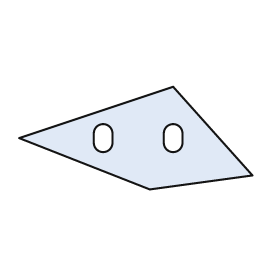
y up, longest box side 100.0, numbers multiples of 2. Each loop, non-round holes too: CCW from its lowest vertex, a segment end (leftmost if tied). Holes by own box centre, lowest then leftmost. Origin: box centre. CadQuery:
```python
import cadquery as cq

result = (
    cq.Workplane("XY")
    .moveTo(6.0, -22.0)
    .lineTo(50.0, -16.0)
    .lineTo(16.0, 22.0)
    .lineTo(-50.0, 0.0)
    .close()
    .moveTo(-18.0, -2.0)
    .threePointArc((-14.0, -6.0), (-10.0, -2.0))
    .lineTo(-10.0, 2.0)
    .threePointArc((-14.0, 6.0), (-18.0, 2.0))
    .close()
    .moveTo(12.0, -2.0)
    .threePointArc((16.0, -6.0), (20.0, -2.0))
    .lineTo(20.0, 2.0)
    .threePointArc((16.0, 6.0), (12.0, 2.0))
    .close()
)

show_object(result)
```